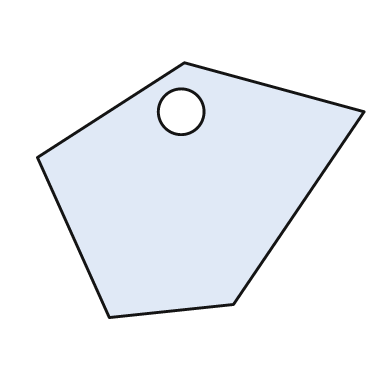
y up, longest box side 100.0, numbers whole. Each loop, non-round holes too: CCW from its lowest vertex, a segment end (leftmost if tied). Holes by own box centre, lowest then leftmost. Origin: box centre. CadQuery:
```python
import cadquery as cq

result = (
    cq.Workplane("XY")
    .moveTo(-28.0, -39.0)
    .lineTo(10.0, -35.0)
    .lineTo(50.0, 24.0)
    .lineTo(-5.0, 39.0)
    .lineTo(-50.0, 10.0)
    .close()
    .moveTo(-6.0, 24.0)
    .circle(7.0)
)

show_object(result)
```